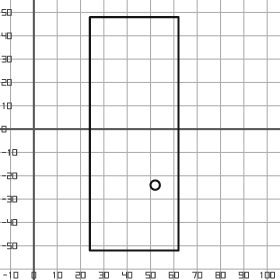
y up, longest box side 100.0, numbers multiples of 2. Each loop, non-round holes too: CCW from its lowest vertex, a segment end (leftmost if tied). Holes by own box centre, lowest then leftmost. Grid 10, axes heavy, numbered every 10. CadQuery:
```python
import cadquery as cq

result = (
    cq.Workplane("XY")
    .moveTo(24.0, -52.0)
    .lineTo(62.0, -52.0)
    .lineTo(62.0, 48.0)
    .lineTo(24.0, 48.0)
    .close()
    .moveTo(52.0, -24.0)
    .circle(2.0)
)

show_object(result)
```